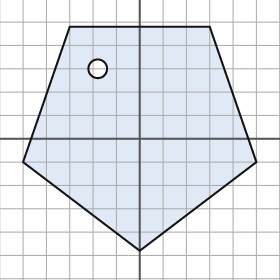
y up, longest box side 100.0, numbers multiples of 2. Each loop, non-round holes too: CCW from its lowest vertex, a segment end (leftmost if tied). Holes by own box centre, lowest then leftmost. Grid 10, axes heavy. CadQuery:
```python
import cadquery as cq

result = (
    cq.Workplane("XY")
    .moveTo(0.0, -48.0)
    .lineTo(50.0, -10.0)
    .lineTo(30.0, 48.0)
    .lineTo(-30.0, 48.0)
    .lineTo(-50.0, -10.0)
    .close()
    .moveTo(-18.0, 30.0)
    .circle(4.0)
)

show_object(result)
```